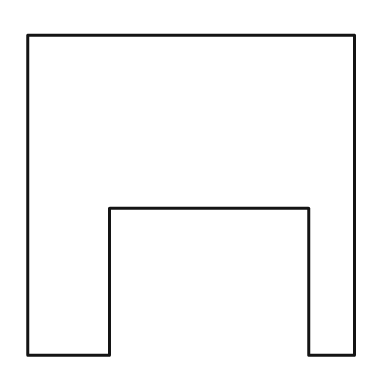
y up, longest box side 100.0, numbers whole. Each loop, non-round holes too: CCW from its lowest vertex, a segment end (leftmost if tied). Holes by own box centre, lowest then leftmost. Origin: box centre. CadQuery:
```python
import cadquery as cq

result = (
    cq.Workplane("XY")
    .moveTo(-50.0, -49.0)
    .lineTo(-25.0, -49.0)
    .lineTo(-25.0, -4.0)
    .lineTo(36.0, -4.0)
    .lineTo(36.0, -49.0)
    .lineTo(50.0, -49.0)
    .lineTo(50.0, 49.0)
    .lineTo(-50.0, 49.0)
    .close()
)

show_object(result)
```